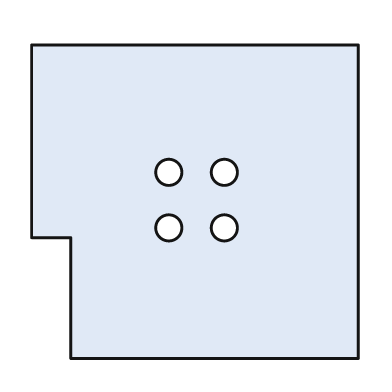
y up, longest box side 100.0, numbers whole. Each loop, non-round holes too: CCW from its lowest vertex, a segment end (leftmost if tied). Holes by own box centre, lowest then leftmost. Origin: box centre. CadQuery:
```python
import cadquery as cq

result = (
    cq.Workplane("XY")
    .moveTo(-38.0, -48.0)
    .lineTo(50.0, -48.0)
    .lineTo(50.0, 48.0)
    .lineTo(-50.0, 48.0)
    .lineTo(-50.0, -11.0)
    .lineTo(-38.0, -11.0)
    .close()
    .moveTo(-8.0, -8.0)
    .circle(4.0)
    .moveTo(9.0, -8.0)
    .circle(4.0)
    .moveTo(-8.0, 9.0)
    .circle(4.0)
    .moveTo(9.0, 9.0)
    .circle(4.0)
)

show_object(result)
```